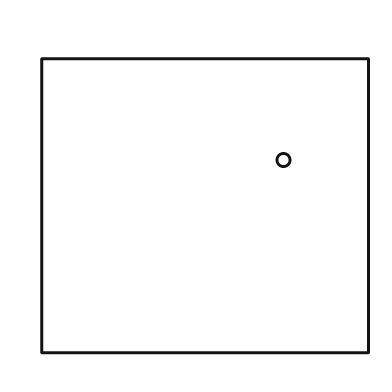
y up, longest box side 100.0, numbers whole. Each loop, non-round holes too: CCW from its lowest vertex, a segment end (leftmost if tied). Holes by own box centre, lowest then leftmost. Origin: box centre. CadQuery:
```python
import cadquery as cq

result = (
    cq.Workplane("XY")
    .moveTo(-50.0, -45.0)
    .lineTo(50.0, -45.0)
    .lineTo(50.0, 45.0)
    .lineTo(-50.0, 45.0)
    .close()
    .moveTo(24.0, 14.0)
    .circle(2.0)
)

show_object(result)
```